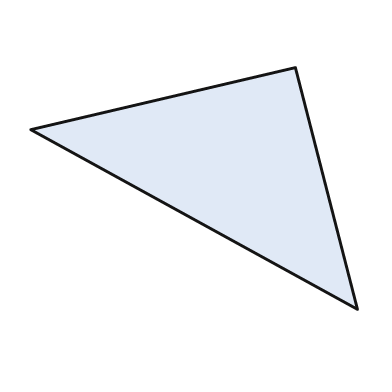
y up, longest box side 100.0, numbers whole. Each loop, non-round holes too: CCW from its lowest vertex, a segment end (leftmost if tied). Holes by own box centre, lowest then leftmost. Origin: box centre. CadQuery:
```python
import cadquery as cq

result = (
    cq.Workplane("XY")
    .moveTo(50.0, -37.0)
    .lineTo(31.0, 37.0)
    .lineTo(-50.0, 18.0)
    .close()
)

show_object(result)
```